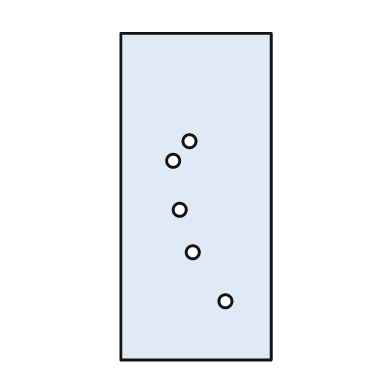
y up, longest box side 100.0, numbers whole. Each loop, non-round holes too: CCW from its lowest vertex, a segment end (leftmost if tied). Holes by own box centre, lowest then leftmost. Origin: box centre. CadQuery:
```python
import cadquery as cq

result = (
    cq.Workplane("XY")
    .moveTo(-23.0, -50.0)
    .lineTo(23.0, -50.0)
    .lineTo(23.0, 50.0)
    .lineTo(-23.0, 50.0)
    .close()
    .moveTo(9.0, -32.0)
    .circle(2.0)
    .moveTo(-1.0, -17.0)
    .circle(2.0)
    .moveTo(-5.0, -4.0)
    .circle(2.0)
    .moveTo(-7.0, 11.0)
    .circle(2.0)
    .moveTo(-2.0, 17.0)
    .circle(2.0)
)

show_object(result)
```